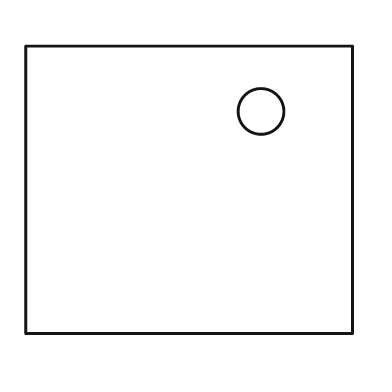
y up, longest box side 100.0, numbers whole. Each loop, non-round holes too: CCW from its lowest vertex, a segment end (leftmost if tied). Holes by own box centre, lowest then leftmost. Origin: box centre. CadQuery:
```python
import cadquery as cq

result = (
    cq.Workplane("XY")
    .moveTo(-50.0, -44.0)
    .lineTo(50.0, -44.0)
    .lineTo(50.0, 44.0)
    .lineTo(-50.0, 44.0)
    .close()
    .moveTo(22.0, 24.0)
    .circle(7.0)
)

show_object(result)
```